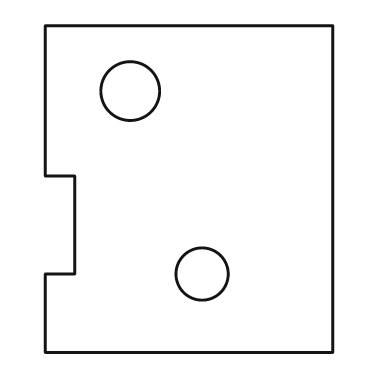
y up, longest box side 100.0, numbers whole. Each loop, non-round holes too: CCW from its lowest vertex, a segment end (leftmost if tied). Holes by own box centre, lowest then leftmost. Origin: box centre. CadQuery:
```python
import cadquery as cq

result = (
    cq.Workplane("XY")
    .moveTo(-44.0, -50.0)
    .lineTo(44.0, -50.0)
    .lineTo(44.0, 50.0)
    .lineTo(-44.0, 50.0)
    .lineTo(-44.0, 4.0)
    .lineTo(-35.0, 4.0)
    .lineTo(-35.0, -26.0)
    .lineTo(-44.0, -26.0)
    .close()
    .moveTo(4.0, -26.0)
    .circle(8.0)
    .moveTo(-18.0, 30.0)
    .circle(9.0)
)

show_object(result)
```